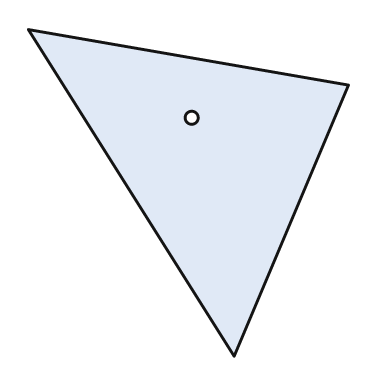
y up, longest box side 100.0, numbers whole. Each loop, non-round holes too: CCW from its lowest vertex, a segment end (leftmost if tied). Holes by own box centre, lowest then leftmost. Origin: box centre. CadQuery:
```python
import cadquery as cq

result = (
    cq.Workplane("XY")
    .moveTo(14.0, -50.0)
    .lineTo(49.0, 33.0)
    .lineTo(-49.0, 50.0)
    .close()
    .moveTo(1.0, 23.0)
    .circle(2.0)
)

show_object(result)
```